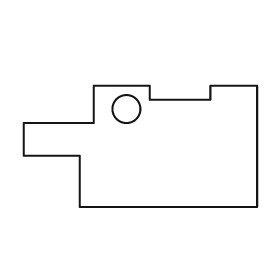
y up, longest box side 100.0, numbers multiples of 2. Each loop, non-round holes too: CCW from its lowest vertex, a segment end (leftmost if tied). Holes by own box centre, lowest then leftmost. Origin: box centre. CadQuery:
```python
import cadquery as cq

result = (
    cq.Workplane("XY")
    .moveTo(-26.0, -26.0)
    .lineTo(50.0, -26.0)
    .lineTo(50.0, 26.0)
    .lineTo(30.0, 26.0)
    .lineTo(30.0, 20.0)
    .lineTo(4.0, 20.0)
    .lineTo(4.0, 26.0)
    .lineTo(-20.0, 26.0)
    .lineTo(-20.0, 10.0)
    .lineTo(-50.0, 10.0)
    .lineTo(-50.0, -4.0)
    .lineTo(-26.0, -4.0)
    .close()
    .moveTo(-6.0, 16.0)
    .circle(6.0)
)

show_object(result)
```